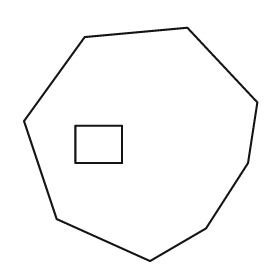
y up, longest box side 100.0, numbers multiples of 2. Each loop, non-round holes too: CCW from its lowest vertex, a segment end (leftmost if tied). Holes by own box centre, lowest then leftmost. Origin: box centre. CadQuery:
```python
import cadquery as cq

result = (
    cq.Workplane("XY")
    .moveTo(4.0, -50.0)
    .lineTo(28.0, -36.0)
    .lineTo(46.0, -8.0)
    .lineTo(50.0, 18.0)
    .lineTo(20.0, 50.0)
    .lineTo(-24.0, 46.0)
    .lineTo(-50.0, 10.0)
    .lineTo(-36.0, -32.0)
    .close()
    .moveTo(-28.0, -8.0)
    .lineTo(-8.0, -8.0)
    .lineTo(-8.0, 8.0)
    .lineTo(-28.0, 8.0)
    .close()
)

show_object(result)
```